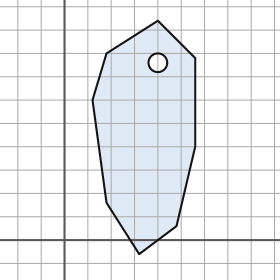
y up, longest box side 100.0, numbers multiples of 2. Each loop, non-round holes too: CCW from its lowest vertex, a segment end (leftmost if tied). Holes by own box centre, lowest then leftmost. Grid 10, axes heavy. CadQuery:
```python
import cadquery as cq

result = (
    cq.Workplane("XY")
    .moveTo(32.0, -6.0)
    .lineTo(48.0, 6.0)
    .lineTo(56.0, 40.0)
    .lineTo(56.0, 78.0)
    .lineTo(40.0, 94.0)
    .lineTo(18.0, 80.0)
    .lineTo(12.0, 60.0)
    .lineTo(18.0, 16.0)
    .close()
    .moveTo(40.0, 76.0)
    .circle(4.0)
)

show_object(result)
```